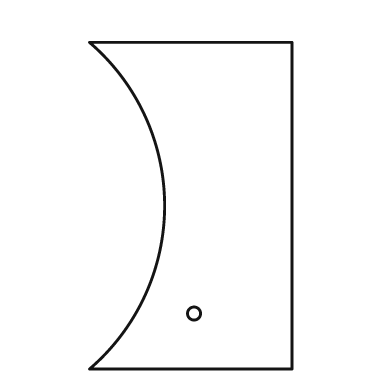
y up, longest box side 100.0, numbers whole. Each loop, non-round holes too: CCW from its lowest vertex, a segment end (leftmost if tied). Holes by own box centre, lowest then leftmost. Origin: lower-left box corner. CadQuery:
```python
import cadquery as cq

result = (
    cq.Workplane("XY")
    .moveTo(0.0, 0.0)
    .lineTo(62.0, 0.0)
    .lineTo(62.0, 100.0)
    .lineTo(0.0, 100.0)
    .threePointArc((23.0, 50.0), (0.0, 0.0))
    .close()
    .moveTo(32.0, 17.0)
    .circle(2.0)
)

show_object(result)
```